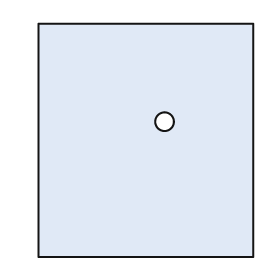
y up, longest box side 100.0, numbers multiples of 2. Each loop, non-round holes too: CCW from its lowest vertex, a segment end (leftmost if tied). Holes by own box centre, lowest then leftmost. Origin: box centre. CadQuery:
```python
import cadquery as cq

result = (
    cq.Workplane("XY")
    .moveTo(-46.0, -50.0)
    .lineTo(46.0, -50.0)
    .lineTo(46.0, 50.0)
    .lineTo(-46.0, 50.0)
    .close()
    .moveTo(8.0, 8.0)
    .circle(4.0)
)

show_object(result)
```